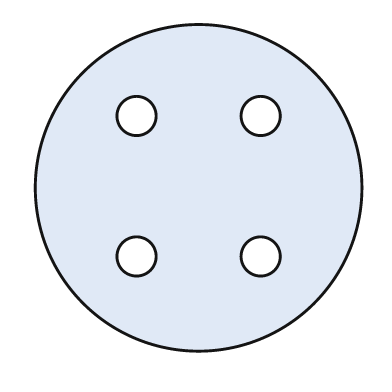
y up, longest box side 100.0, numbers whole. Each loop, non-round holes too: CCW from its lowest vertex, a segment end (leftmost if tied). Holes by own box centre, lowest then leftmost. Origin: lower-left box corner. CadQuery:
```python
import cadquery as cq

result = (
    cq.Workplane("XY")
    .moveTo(50.0, 50.0)
    .circle(50.0)
    .moveTo(31.0, 29.0)
    .circle(6.0)
    .moveTo(69.0, 29.0)
    .circle(6.0)
    .moveTo(31.0, 72.0)
    .circle(6.0)
    .moveTo(69.0, 72.0)
    .circle(6.0)
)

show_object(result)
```